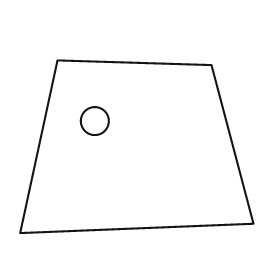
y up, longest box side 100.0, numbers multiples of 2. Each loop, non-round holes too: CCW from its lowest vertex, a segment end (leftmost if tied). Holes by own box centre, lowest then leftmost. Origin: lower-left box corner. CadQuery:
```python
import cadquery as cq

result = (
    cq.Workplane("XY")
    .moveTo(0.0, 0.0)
    .lineTo(100.0, 4.0)
    .lineTo(82.0, 72.0)
    .lineTo(16.0, 74.0)
    .close()
    .moveTo(32.0, 48.0)
    .circle(6.0)
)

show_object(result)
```